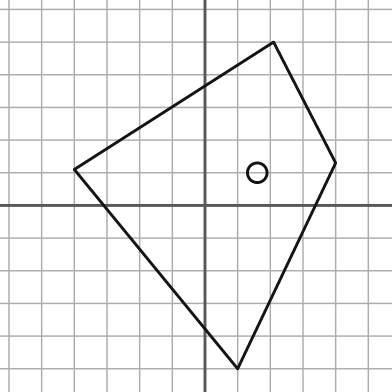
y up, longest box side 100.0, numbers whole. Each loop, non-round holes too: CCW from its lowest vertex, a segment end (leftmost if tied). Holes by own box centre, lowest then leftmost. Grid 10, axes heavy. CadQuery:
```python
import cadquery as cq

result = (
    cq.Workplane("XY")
    .moveTo(10.0, -50.0)
    .lineTo(40.0, 13.0)
    .lineTo(21.0, 50.0)
    .lineTo(-40.0, 11.0)
    .close()
    .moveTo(16.0, 10.0)
    .circle(3.0)
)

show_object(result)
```